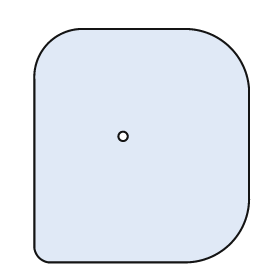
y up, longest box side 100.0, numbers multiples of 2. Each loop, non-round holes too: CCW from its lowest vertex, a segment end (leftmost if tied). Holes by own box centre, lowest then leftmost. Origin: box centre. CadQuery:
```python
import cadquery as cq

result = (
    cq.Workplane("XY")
    .moveTo(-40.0, -50.0)
    .lineTo(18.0, -50.0)
    .threePointArc((38.0, -42.0), (46.0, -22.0))
    .lineTo(46.0, 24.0)
    .threePointArc((38.0, 42.0), (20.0, 50.0))
    .lineTo(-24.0, 50.0)
    .threePointArc((-40.0, 44.0), (-46.0, 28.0))
    .lineTo(-46.0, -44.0)
    .threePointArc((-44.0, -48.0), (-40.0, -50.0))
    .close()
    .moveTo(-8.0, 4.0)
    .circle(2.0)
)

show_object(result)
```